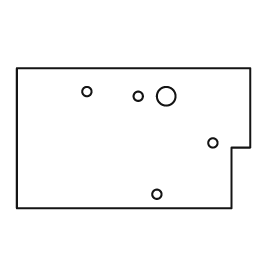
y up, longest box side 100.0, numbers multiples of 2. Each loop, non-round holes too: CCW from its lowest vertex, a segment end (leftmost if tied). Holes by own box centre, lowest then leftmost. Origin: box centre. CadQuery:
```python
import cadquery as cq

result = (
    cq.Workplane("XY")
    .moveTo(-50.0, -30.0)
    .lineTo(42.0, -30.0)
    .lineTo(42.0, -4.0)
    .lineTo(50.0, -4.0)
    .lineTo(50.0, 30.0)
    .lineTo(-50.0, 30.0)
    .close()
    .moveTo(10.0, -24.0)
    .circle(2.0)
    .moveTo(34.0, -2.0)
    .circle(2.0)
    .moveTo(2.0, 18.0)
    .circle(2.0)
    .moveTo(14.0, 18.0)
    .circle(4.0)
    .moveTo(-20.0, 20.0)
    .circle(2.0)
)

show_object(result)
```